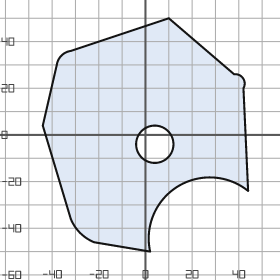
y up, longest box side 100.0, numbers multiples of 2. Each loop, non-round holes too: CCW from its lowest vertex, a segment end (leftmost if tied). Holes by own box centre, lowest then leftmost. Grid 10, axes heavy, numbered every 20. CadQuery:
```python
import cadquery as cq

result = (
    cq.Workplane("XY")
    .moveTo(2.0, -50.0)
    .threePointArc((14.0, -22.0), (44.0, -24.0))
    .lineTo(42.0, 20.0)
    .threePointArc((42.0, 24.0), (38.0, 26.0))
    .lineTo(10.0, 50.0)
    .lineTo(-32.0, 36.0)
    .threePointArc((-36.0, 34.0), (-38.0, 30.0))
    .lineTo(-44.0, 4.0)
    .lineTo(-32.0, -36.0)
    .threePointArc((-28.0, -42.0), (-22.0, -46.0))
    .close()
    .moveTo(4.0, -4.0)
    .circle(8.0)
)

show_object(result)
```